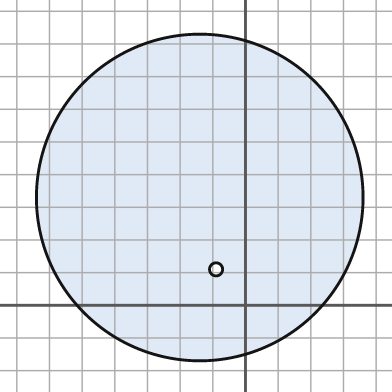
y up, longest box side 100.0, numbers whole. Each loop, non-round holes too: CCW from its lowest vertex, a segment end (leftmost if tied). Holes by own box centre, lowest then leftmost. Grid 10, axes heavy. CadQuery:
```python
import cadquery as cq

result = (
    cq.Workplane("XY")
    .moveTo(-14.0, 33.0)
    .circle(50.0)
    .moveTo(-9.0, 11.0)
    .circle(2.0)
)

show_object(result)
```